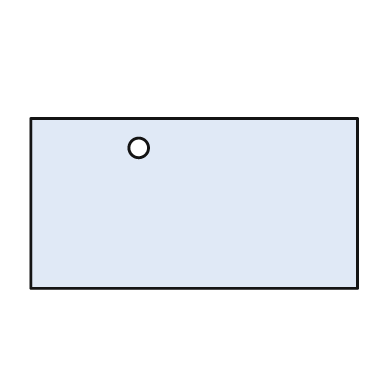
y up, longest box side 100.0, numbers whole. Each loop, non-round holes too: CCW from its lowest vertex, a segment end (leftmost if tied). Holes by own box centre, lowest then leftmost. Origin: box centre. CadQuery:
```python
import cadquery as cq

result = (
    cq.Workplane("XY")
    .moveTo(-50.0, -26.0)
    .lineTo(50.0, -26.0)
    .lineTo(50.0, 26.0)
    .lineTo(-50.0, 26.0)
    .close()
    .moveTo(-17.0, 17.0)
    .circle(3.0)
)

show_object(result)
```